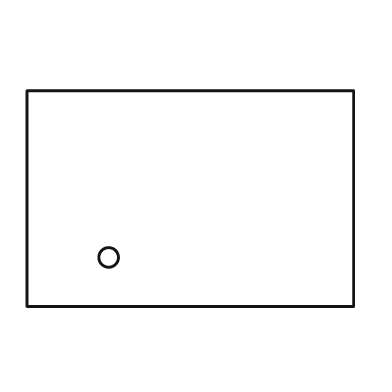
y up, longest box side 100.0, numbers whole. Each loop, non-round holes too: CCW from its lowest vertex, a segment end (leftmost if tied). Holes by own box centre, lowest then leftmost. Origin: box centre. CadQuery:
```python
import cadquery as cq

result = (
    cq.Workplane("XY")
    .moveTo(-50.0, -33.0)
    .lineTo(50.0, -33.0)
    .lineTo(50.0, 33.0)
    .lineTo(-50.0, 33.0)
    .close()
    .moveTo(-25.0, -18.0)
    .circle(3.0)
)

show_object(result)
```